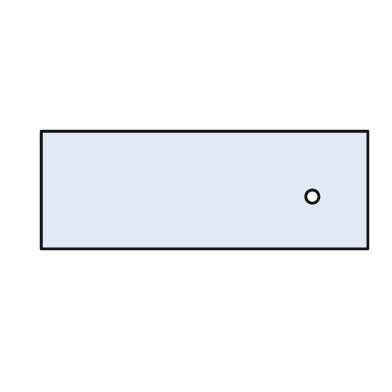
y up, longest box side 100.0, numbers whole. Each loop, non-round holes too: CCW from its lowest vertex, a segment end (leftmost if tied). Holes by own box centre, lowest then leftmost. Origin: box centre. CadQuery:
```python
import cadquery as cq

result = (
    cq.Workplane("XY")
    .moveTo(-50.0, -18.0)
    .lineTo(50.0, -18.0)
    .lineTo(50.0, 18.0)
    .lineTo(-50.0, 18.0)
    .close()
    .moveTo(33.0, -2.0)
    .circle(2.0)
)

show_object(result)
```